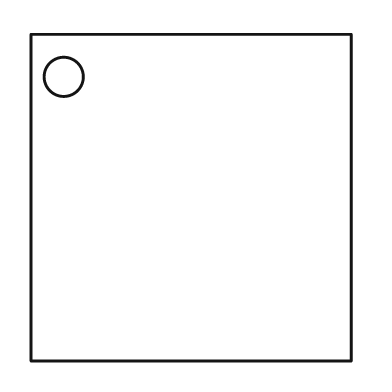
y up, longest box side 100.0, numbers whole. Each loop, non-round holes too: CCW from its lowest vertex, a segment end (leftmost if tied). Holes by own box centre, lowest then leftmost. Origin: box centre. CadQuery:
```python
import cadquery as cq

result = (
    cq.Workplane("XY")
    .moveTo(-49.0, -50.0)
    .lineTo(49.0, -50.0)
    .lineTo(49.0, 50.0)
    .lineTo(-49.0, 50.0)
    .close()
    .moveTo(-39.0, 37.0)
    .circle(6.0)
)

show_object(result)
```